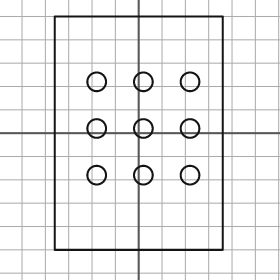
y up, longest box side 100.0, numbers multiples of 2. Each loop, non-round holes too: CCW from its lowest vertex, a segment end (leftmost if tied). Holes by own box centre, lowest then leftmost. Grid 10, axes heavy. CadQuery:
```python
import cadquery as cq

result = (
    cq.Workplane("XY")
    .moveTo(-36.0, -50.0)
    .lineTo(36.0, -50.0)
    .lineTo(36.0, 50.0)
    .lineTo(-36.0, 50.0)
    .close()
    .moveTo(-18.0, -18.0)
    .circle(4.0)
    .moveTo(2.0, -18.0)
    .circle(4.0)
    .moveTo(22.0, -18.0)
    .circle(4.0)
    .moveTo(-18.0, 2.0)
    .circle(4.0)
    .moveTo(2.0, 2.0)
    .circle(4.0)
    .moveTo(22.0, 2.0)
    .circle(4.0)
    .moveTo(-18.0, 22.0)
    .circle(4.0)
    .moveTo(2.0, 22.0)
    .circle(4.0)
    .moveTo(22.0, 22.0)
    .circle(4.0)
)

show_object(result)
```